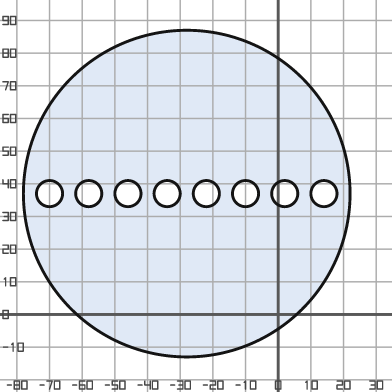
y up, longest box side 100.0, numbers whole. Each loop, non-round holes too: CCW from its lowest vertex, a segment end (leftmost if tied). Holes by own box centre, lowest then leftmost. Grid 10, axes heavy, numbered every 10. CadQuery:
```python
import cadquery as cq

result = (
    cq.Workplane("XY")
    .moveTo(-28.0, 37.0)
    .circle(50.0)
    .moveTo(-70.0, 37.0)
    .circle(4.0)
    .moveTo(-58.0, 37.0)
    .circle(4.0)
    .moveTo(-46.0, 37.0)
    .circle(4.0)
    .moveTo(-34.0, 37.0)
    .circle(4.0)
    .moveTo(-22.0, 37.0)
    .circle(4.0)
    .moveTo(-10.0, 37.0)
    .circle(4.0)
    .moveTo(2.0, 37.0)
    .circle(4.0)
    .moveTo(14.0, 37.0)
    .circle(4.0)
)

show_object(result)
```